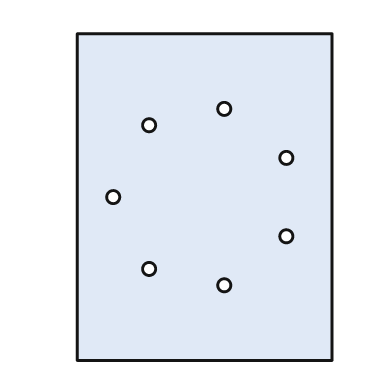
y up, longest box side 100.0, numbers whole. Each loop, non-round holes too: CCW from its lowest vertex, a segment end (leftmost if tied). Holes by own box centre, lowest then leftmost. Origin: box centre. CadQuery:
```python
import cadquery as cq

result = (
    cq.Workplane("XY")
    .moveTo(-39.0, -50.0)
    .lineTo(39.0, -50.0)
    .lineTo(39.0, 50.0)
    .lineTo(-39.0, 50.0)
    .close()
    .moveTo(6.0, -27.0)
    .circle(2.0)
    .moveTo(-17.0, -22.0)
    .circle(2.0)
    .moveTo(25.0, -12.0)
    .circle(2.0)
    .moveTo(-28.0, 0.0)
    .circle(2.0)
    .moveTo(25.0, 12.0)
    .circle(2.0)
    .moveTo(-17.0, 22.0)
    .circle(2.0)
    .moveTo(6.0, 27.0)
    .circle(2.0)
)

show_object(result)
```